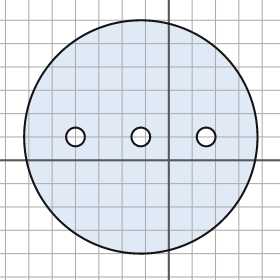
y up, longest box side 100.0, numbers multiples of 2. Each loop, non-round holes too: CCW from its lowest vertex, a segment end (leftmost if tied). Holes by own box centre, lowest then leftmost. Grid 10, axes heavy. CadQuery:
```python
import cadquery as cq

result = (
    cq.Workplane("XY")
    .moveTo(-12.0, 10.0)
    .circle(50.0)
    .moveTo(-40.0, 10.0)
    .circle(4.0)
    .moveTo(-12.0, 10.0)
    .circle(4.0)
    .moveTo(16.0, 10.0)
    .circle(4.0)
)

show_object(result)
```